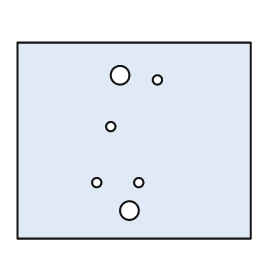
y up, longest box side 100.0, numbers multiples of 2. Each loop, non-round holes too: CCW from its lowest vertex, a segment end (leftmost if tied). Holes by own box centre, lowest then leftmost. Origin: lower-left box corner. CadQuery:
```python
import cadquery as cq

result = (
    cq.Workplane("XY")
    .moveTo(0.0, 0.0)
    .lineTo(100.0, 0.0)
    .lineTo(100.0, 84.0)
    .lineTo(0.0, 84.0)
    .close()
    .moveTo(48.0, 12.0)
    .circle(4.0)
    .moveTo(34.0, 24.0)
    .circle(2.0)
    .moveTo(52.0, 24.0)
    .circle(2.0)
    .moveTo(40.0, 48.0)
    .circle(2.0)
    .moveTo(60.0, 68.0)
    .circle(2.0)
    .moveTo(44.0, 70.0)
    .circle(4.0)
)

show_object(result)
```